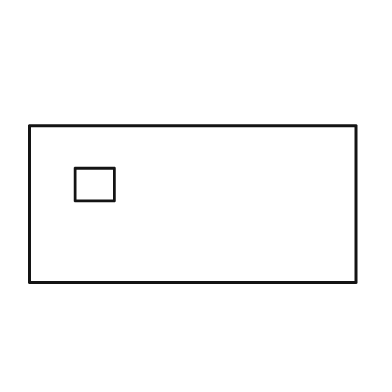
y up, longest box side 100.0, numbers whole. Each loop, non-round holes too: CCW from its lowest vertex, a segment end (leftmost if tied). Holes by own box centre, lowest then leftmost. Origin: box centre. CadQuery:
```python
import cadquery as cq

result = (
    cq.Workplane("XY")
    .moveTo(-50.0, -24.0)
    .lineTo(50.0, -24.0)
    .lineTo(50.0, 24.0)
    .lineTo(-50.0, 24.0)
    .close()
    .moveTo(-36.0, 1.0)
    .lineTo(-24.0, 1.0)
    .lineTo(-24.0, 11.0)
    .lineTo(-36.0, 11.0)
    .close()
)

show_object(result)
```